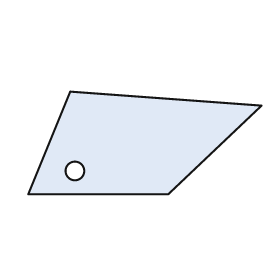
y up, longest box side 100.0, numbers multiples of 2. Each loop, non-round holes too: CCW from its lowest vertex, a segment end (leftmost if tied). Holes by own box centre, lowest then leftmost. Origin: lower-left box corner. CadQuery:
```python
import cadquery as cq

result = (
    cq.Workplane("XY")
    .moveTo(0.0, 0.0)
    .lineTo(60.0, 0.0)
    .lineTo(100.0, 38.0)
    .lineTo(18.0, 44.0)
    .close()
    .moveTo(20.0, 10.0)
    .circle(4.0)
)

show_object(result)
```